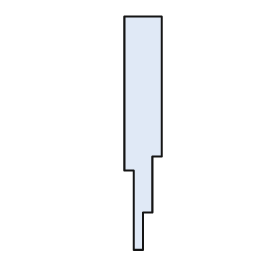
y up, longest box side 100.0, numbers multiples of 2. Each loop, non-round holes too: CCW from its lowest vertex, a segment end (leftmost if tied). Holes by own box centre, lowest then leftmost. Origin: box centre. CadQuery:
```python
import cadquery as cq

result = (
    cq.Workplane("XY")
    .moveTo(-4.0, -50.0)
    .lineTo(0.0, -50.0)
    .lineTo(0.0, -34.0)
    .lineTo(4.0, -34.0)
    .lineTo(4.0, -10.0)
    .lineTo(8.0, -10.0)
    .lineTo(8.0, 50.0)
    .lineTo(-8.0, 50.0)
    .lineTo(-8.0, -16.0)
    .lineTo(-4.0, -16.0)
    .close()
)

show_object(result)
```